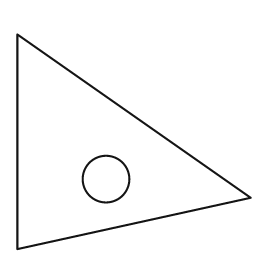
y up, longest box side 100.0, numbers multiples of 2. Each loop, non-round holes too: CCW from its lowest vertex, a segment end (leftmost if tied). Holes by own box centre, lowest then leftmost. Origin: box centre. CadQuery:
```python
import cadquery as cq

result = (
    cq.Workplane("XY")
    .moveTo(-50.0, -46.0)
    .lineTo(50.0, -24.0)
    .lineTo(-50.0, 46.0)
    .close()
    .moveTo(-12.0, -16.0)
    .circle(10.0)
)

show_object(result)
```